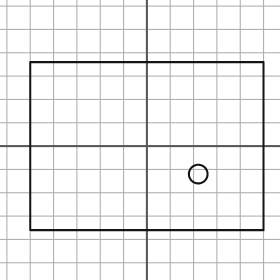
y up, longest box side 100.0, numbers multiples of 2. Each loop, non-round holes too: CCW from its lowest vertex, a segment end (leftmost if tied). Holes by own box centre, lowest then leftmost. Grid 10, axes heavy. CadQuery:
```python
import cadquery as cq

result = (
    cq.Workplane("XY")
    .moveTo(-50.0, -36.0)
    .lineTo(50.0, -36.0)
    .lineTo(50.0, 36.0)
    .lineTo(-50.0, 36.0)
    .close()
    .moveTo(22.0, -12.0)
    .circle(4.0)
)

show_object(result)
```